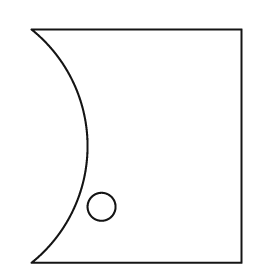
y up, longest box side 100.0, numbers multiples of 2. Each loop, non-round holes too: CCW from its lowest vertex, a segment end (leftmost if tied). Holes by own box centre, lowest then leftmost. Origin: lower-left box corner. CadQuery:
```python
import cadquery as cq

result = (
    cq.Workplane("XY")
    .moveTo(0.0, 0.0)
    .lineTo(90.0, 0.0)
    .lineTo(90.0, 100.0)
    .lineTo(0.0, 100.0)
    .threePointArc((24.0, 50.0), (0.0, 0.0))
    .close()
    .moveTo(30.0, 24.0)
    .circle(6.0)
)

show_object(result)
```